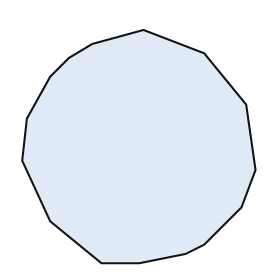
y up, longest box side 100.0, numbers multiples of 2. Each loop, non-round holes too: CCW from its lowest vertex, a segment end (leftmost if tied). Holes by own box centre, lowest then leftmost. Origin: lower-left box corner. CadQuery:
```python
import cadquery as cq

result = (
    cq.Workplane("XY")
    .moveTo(34.0, 0.0)
    .lineTo(50.0, 0.0)
    .lineTo(70.0, 4.0)
    .lineTo(78.0, 8.0)
    .lineTo(94.0, 24.0)
    .lineTo(100.0, 40.0)
    .lineTo(96.0, 68.0)
    .lineTo(78.0, 90.0)
    .lineTo(52.0, 100.0)
    .lineTo(30.0, 94.0)
    .lineTo(20.0, 88.0)
    .lineTo(12.0, 80.0)
    .lineTo(2.0, 62.0)
    .lineTo(0.0, 44.0)
    .lineTo(12.0, 18.0)
    .close()
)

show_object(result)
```